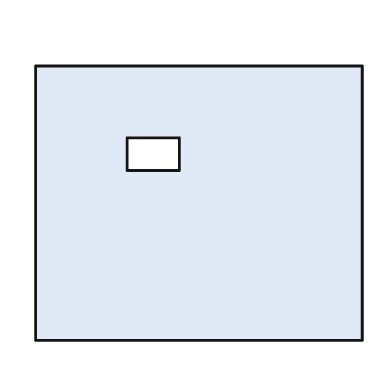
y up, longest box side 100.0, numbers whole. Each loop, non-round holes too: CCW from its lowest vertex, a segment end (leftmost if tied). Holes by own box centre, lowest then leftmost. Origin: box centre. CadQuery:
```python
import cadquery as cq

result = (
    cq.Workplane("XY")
    .moveTo(-50.0, -42.0)
    .lineTo(50.0, -42.0)
    .lineTo(50.0, 42.0)
    .lineTo(-50.0, 42.0)
    .close()
    .moveTo(-22.0, 10.0)
    .lineTo(-6.0, 10.0)
    .lineTo(-6.0, 20.0)
    .lineTo(-22.0, 20.0)
    .close()
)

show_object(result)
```